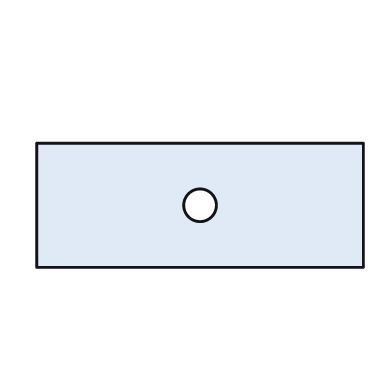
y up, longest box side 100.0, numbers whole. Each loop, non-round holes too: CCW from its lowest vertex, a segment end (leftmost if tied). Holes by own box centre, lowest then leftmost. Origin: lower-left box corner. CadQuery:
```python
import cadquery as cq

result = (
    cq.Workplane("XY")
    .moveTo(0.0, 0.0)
    .lineTo(100.0, 0.0)
    .lineTo(100.0, 38.0)
    .lineTo(0.0, 38.0)
    .close()
    .moveTo(50.0, 19.0)
    .circle(5.0)
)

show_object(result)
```